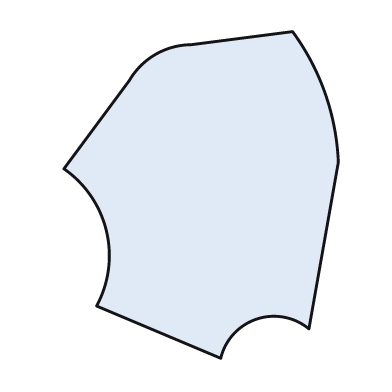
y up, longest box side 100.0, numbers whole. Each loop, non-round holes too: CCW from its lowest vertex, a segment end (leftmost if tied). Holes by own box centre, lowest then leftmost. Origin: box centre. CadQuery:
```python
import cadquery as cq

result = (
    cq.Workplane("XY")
    .moveTo(6.0, -50.0)
    .threePointArc((17.0, -38.0), (33.0, -41.0))
    .lineTo(42.0, 10.0)
    .threePointArc((38.0, 31.0), (28.0, 50.0))
    .lineTo(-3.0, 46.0)
    .threePointArc((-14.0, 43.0), (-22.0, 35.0))
    .lineTo(-42.0, 8.0)
    .threePointArc((-29.0, -11.0), (-32.0, -34.0))
    .close()
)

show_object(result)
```